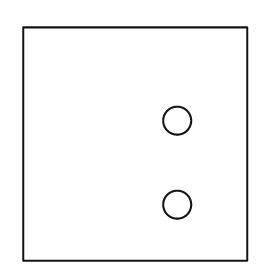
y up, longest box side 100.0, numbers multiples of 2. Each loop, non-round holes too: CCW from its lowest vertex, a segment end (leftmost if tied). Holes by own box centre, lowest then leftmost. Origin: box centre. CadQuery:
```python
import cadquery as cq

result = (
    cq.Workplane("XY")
    .moveTo(-48.0, -50.0)
    .lineTo(48.0, -50.0)
    .lineTo(48.0, 50.0)
    .lineTo(-48.0, 50.0)
    .close()
    .moveTo(18.0, -26.0)
    .circle(6.0)
    .moveTo(18.0, 10.0)
    .circle(6.0)
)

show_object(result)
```